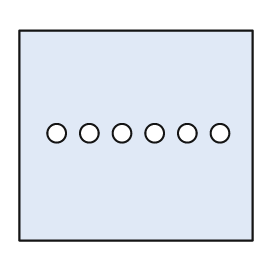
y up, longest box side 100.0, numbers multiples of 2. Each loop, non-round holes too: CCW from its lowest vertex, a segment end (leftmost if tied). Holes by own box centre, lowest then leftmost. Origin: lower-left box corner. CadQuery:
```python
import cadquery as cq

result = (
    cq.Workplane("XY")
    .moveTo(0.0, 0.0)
    .lineTo(100.0, 0.0)
    .lineTo(100.0, 90.0)
    .lineTo(0.0, 90.0)
    .close()
    .moveTo(16.0, 46.0)
    .circle(4.0)
    .moveTo(30.0, 46.0)
    .circle(4.0)
    .moveTo(44.0, 46.0)
    .circle(4.0)
    .moveTo(58.0, 46.0)
    .circle(4.0)
    .moveTo(72.0, 46.0)
    .circle(4.0)
    .moveTo(86.0, 46.0)
    .circle(4.0)
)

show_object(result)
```